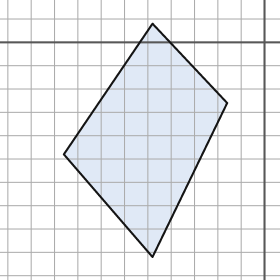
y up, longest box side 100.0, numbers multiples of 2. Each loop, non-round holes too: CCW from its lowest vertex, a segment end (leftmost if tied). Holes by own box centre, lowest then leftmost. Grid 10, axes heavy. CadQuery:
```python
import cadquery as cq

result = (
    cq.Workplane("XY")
    .moveTo(-48.0, -92.0)
    .lineTo(-16.0, -26.0)
    .lineTo(-48.0, 8.0)
    .lineTo(-86.0, -48.0)
    .close()
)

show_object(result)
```